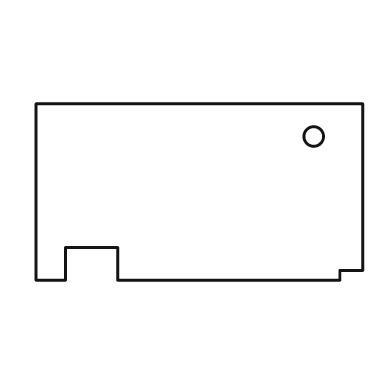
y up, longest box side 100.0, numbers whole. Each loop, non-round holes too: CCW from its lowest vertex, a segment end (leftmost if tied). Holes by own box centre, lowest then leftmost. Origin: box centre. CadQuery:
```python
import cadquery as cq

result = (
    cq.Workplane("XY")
    .moveTo(-50.0, -27.0)
    .lineTo(-41.0, -27.0)
    .lineTo(-41.0, -17.0)
    .lineTo(-25.0, -17.0)
    .lineTo(-25.0, -27.0)
    .lineTo(43.0, -27.0)
    .lineTo(43.0, -24.0)
    .lineTo(50.0, -24.0)
    .lineTo(50.0, 27.0)
    .lineTo(-50.0, 27.0)
    .close()
    .moveTo(35.0, 17.0)
    .circle(3.0)
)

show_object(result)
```